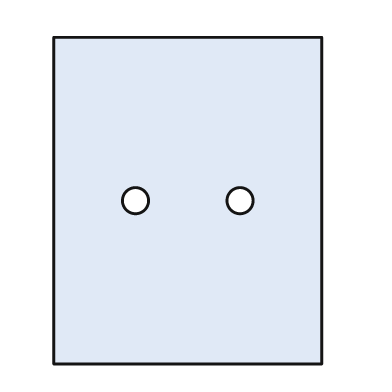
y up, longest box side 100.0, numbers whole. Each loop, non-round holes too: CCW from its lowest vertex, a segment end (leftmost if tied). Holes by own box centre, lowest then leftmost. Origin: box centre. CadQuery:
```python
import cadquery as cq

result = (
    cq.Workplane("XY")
    .moveTo(-41.0, -50.0)
    .lineTo(41.0, -50.0)
    .lineTo(41.0, 50.0)
    .lineTo(-41.0, 50.0)
    .close()
    .moveTo(-16.0, 0.0)
    .circle(4.0)
    .moveTo(16.0, 0.0)
    .circle(4.0)
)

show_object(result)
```